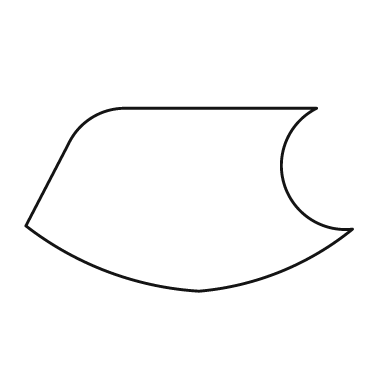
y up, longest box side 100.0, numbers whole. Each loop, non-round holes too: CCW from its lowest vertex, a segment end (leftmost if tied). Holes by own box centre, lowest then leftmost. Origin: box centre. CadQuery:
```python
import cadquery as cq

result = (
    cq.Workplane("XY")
    .moveTo(3.0, -28.0)
    .threePointArc((28.0, -22.0), (50.0, -9.0))
    .threePointArc((29.0, 5.0), (39.0, 28.0))
    .lineTo(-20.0, 28.0)
    .threePointArc((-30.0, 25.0), (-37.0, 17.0))
    .lineTo(-50.0, -8.0)
    .threePointArc((-25.0, -22.0), (3.0, -28.0))
    .close()
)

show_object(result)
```